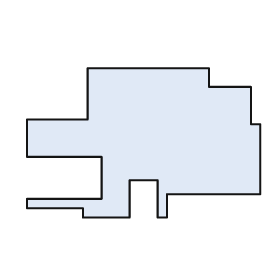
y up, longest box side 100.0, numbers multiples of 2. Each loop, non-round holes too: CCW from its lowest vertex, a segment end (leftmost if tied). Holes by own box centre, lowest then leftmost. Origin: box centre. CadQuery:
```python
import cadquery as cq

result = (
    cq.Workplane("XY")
    .moveTo(-26.0, -32.0)
    .lineTo(-6.0, -32.0)
    .lineTo(-6.0, -16.0)
    .lineTo(6.0, -16.0)
    .lineTo(6.0, -32.0)
    .lineTo(10.0, -32.0)
    .lineTo(10.0, -22.0)
    .lineTo(50.0, -22.0)
    .lineTo(50.0, 8.0)
    .lineTo(46.0, 8.0)
    .lineTo(46.0, 24.0)
    .lineTo(28.0, 24.0)
    .lineTo(28.0, 32.0)
    .lineTo(-24.0, 32.0)
    .lineTo(-24.0, 10.0)
    .lineTo(-50.0, 10.0)
    .lineTo(-50.0, -6.0)
    .lineTo(-18.0, -6.0)
    .lineTo(-18.0, -24.0)
    .lineTo(-50.0, -24.0)
    .lineTo(-50.0, -28.0)
    .lineTo(-26.0, -28.0)
    .close()
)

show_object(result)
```